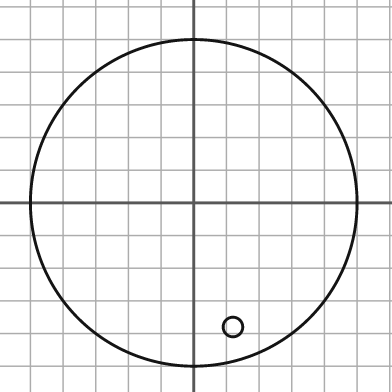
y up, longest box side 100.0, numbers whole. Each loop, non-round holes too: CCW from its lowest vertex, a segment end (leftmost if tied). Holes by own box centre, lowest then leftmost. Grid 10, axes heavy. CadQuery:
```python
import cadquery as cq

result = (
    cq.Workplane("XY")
    .moveTo(0.0, 0.0)
    .circle(50.0)
    .moveTo(12.0, -38.0)
    .circle(3.0)
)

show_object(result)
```